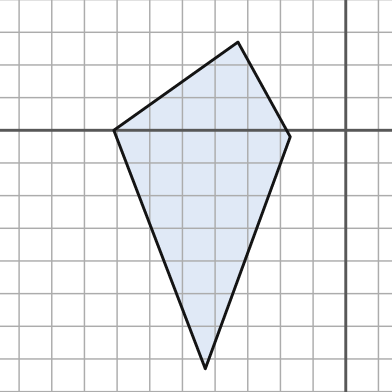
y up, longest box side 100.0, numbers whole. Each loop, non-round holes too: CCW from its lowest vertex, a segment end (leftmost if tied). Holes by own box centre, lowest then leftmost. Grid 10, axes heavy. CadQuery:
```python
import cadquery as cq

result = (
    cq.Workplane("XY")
    .moveTo(-43.0, -73.0)
    .lineTo(-17.0, -2.0)
    .lineTo(-33.0, 27.0)
    .lineTo(-71.0, 0.0)
    .close()
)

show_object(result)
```